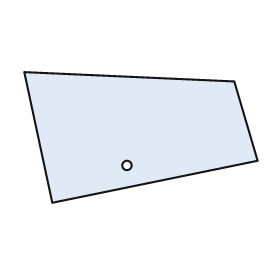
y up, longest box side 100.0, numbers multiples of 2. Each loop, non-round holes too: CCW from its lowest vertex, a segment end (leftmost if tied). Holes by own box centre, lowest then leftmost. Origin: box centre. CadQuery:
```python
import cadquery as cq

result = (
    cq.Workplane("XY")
    .moveTo(-38.0, -28.0)
    .lineTo(50.0, -10.0)
    .lineTo(40.0, 24.0)
    .lineTo(-50.0, 28.0)
    .close()
    .moveTo(-6.0, -12.0)
    .circle(2.0)
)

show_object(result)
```